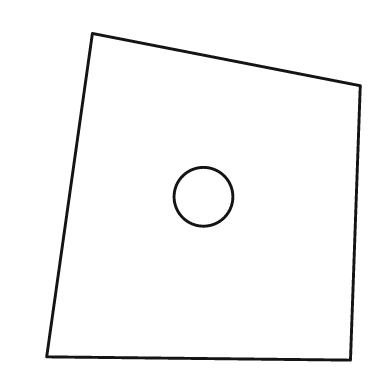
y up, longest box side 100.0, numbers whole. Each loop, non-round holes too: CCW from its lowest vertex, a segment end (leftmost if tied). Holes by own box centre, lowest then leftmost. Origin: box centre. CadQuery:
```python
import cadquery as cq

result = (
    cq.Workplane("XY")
    .moveTo(45.0, -50.0)
    .lineTo(48.0, 34.0)
    .lineTo(-34.0, 50.0)
    .lineTo(-48.0, -49.0)
    .close()
    .moveTo(0.0, 0.0)
    .circle(9.0)
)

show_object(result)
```